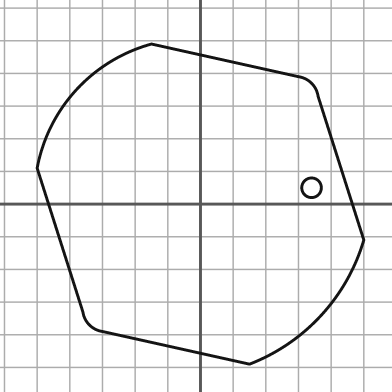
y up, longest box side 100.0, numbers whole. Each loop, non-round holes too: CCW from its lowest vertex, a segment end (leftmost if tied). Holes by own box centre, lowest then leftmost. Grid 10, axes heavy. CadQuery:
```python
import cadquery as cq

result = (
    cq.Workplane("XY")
    .moveTo(15.0, -49.0)
    .threePointArc((37.0, -34.0), (50.0, -11.0))
    .lineTo(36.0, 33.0)
    .threePointArc((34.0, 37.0), (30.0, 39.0))
    .lineTo(-15.0, 49.0)
    .threePointArc((-38.0, 35.0), (-50.0, 11.0))
    .lineTo(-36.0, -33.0)
    .threePointArc((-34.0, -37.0), (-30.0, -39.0))
    .close()
    .moveTo(34.0, 5.0)
    .circle(3.0)
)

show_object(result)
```